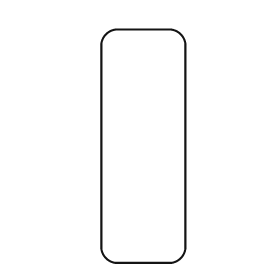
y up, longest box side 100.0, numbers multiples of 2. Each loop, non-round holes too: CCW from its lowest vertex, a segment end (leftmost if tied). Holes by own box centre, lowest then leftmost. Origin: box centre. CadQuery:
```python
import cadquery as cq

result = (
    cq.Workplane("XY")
    .moveTo(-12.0, -50.0)
    .lineTo(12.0, -50.0)
    .threePointArc((16.0, -48.0), (18.0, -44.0))
    .lineTo(18.0, 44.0)
    .threePointArc((16.0, 48.0), (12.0, 50.0))
    .lineTo(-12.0, 50.0)
    .threePointArc((-16.0, 48.0), (-18.0, 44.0))
    .lineTo(-18.0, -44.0)
    .threePointArc((-16.0, -48.0), (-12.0, -50.0))
    .close()
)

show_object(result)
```